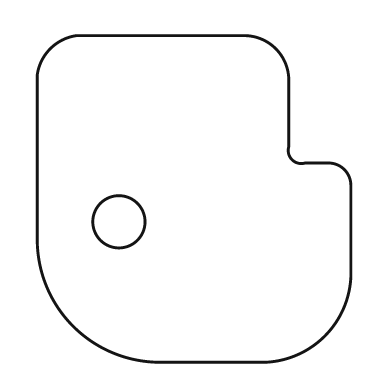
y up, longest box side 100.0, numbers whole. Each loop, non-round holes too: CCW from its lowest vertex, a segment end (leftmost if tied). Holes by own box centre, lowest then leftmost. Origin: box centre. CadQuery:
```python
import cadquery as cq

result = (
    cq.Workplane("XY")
    .moveTo(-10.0, -50.0)
    .lineTo(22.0, -50.0)
    .threePointArc((40.0, -42.0), (48.0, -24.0))
    .lineTo(48.0, 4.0)
    .threePointArc((46.0, 9.0), (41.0, 11.0))
    .lineTo(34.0, 11.0)
    .threePointArc((30.0, 12.0), (29.0, 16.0))
    .lineTo(29.0, 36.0)
    .threePointArc((25.0, 46.0), (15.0, 50.0))
    .lineTo(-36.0, 50.0)
    .threePointArc((-44.0, 46.0), (-48.0, 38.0))
    .lineTo(-48.0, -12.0)
    .threePointArc((-37.0, -39.0), (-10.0, -50.0))
    .close()
    .moveTo(-23.0, -7.0)
    .circle(8.0)
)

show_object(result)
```